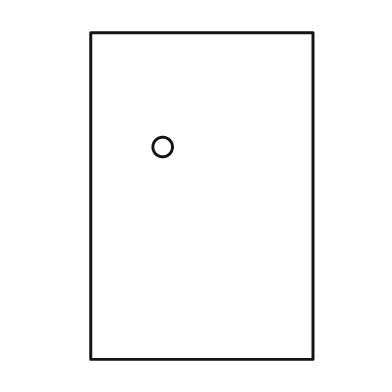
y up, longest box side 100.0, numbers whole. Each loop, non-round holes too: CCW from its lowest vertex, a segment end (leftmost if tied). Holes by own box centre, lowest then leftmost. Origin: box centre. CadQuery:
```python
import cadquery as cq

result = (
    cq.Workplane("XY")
    .moveTo(-34.0, -50.0)
    .lineTo(34.0, -50.0)
    .lineTo(34.0, 50.0)
    .lineTo(-34.0, 50.0)
    .close()
    .moveTo(-12.0, 15.0)
    .circle(3.0)
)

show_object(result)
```